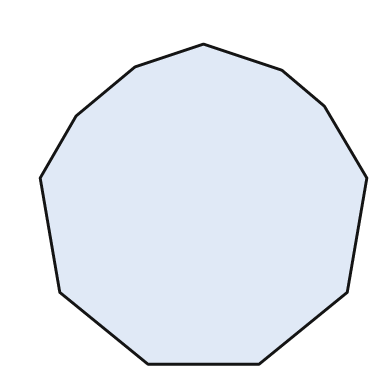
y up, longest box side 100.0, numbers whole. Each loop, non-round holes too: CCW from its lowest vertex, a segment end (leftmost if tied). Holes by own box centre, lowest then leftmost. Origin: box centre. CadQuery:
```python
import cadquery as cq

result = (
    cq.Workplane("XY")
    .moveTo(-17.0, -49.0)
    .lineTo(17.0, -49.0)
    .lineTo(44.0, -27.0)
    .lineTo(50.0, 8.0)
    .lineTo(37.0, 30.0)
    .lineTo(24.0, 41.0)
    .lineTo(0.0, 49.0)
    .lineTo(-21.0, 42.0)
    .lineTo(-39.0, 27.0)
    .lineTo(-50.0, 8.0)
    .lineTo(-44.0, -27.0)
    .close()
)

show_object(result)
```